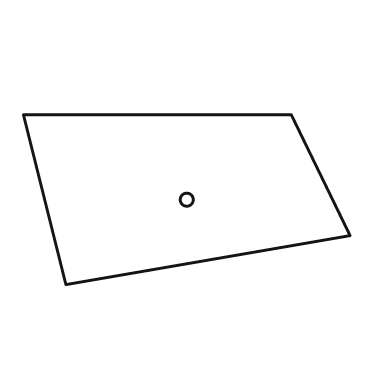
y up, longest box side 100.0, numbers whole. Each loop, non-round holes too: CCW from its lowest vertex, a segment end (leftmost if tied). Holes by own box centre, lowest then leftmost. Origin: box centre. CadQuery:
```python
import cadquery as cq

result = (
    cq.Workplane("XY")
    .moveTo(-37.0, -26.0)
    .lineTo(50.0, -11.0)
    .lineTo(32.0, 26.0)
    .lineTo(-50.0, 26.0)
    .close()
    .moveTo(0.0, 0.0)
    .circle(2.0)
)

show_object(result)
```